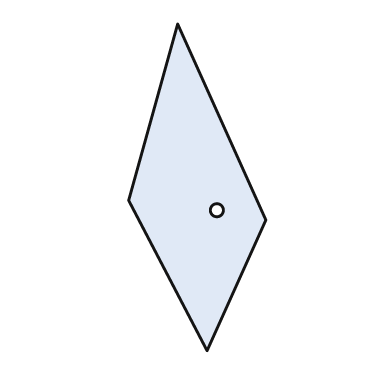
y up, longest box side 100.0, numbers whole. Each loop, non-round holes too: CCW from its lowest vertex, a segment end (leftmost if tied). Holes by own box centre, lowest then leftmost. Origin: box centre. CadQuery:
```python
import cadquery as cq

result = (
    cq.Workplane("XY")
    .moveTo(3.0, -50.0)
    .lineTo(21.0, -10.0)
    .lineTo(-6.0, 50.0)
    .lineTo(-21.0, -4.0)
    .close()
    .moveTo(6.0, -7.0)
    .circle(2.0)
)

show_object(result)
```